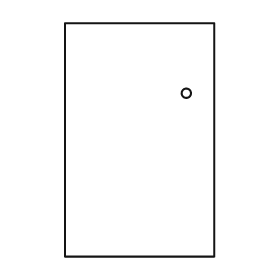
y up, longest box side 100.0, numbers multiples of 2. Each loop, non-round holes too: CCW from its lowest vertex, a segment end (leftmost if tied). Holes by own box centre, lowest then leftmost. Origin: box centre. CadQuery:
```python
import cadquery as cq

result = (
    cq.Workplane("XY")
    .moveTo(-32.0, -50.0)
    .lineTo(32.0, -50.0)
    .lineTo(32.0, 50.0)
    .lineTo(-32.0, 50.0)
    .close()
    .moveTo(20.0, 20.0)
    .circle(2.0)
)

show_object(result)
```